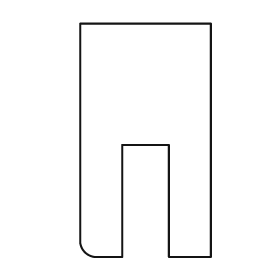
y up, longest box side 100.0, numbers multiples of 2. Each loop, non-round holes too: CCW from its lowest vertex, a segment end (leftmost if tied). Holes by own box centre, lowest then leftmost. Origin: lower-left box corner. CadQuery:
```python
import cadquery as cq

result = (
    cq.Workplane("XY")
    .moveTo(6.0, 0.0)
    .lineTo(18.0, 0.0)
    .lineTo(18.0, 48.0)
    .lineTo(38.0, 48.0)
    .lineTo(38.0, 0.0)
    .lineTo(56.0, 0.0)
    .lineTo(56.0, 100.0)
    .lineTo(0.0, 100.0)
    .lineTo(0.0, 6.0)
    .threePointArc((2.0, 2.0), (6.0, 0.0))
    .close()
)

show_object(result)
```